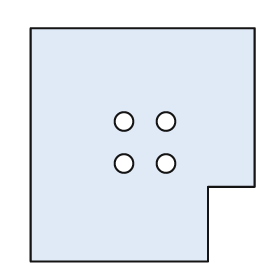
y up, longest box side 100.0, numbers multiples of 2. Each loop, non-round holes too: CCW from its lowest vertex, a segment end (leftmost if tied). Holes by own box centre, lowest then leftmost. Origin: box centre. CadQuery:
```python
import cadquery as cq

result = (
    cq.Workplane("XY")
    .moveTo(-48.0, -50.0)
    .lineTo(28.0, -50.0)
    .lineTo(28.0, -18.0)
    .lineTo(48.0, -18.0)
    .lineTo(48.0, 50.0)
    .lineTo(-48.0, 50.0)
    .close()
    .moveTo(-8.0, -8.0)
    .circle(4.0)
    .moveTo(10.0, -8.0)
    .circle(4.0)
    .moveTo(-8.0, 10.0)
    .circle(4.0)
    .moveTo(10.0, 10.0)
    .circle(4.0)
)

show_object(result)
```